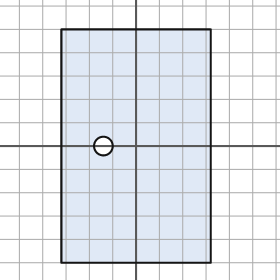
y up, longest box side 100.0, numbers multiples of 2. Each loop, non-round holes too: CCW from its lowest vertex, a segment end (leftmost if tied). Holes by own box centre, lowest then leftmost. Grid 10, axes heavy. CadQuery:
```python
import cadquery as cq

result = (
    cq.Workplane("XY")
    .moveTo(-32.0, -50.0)
    .lineTo(32.0, -50.0)
    .lineTo(32.0, 50.0)
    .lineTo(-32.0, 50.0)
    .close()
    .moveTo(-14.0, 0.0)
    .circle(4.0)
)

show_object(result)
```